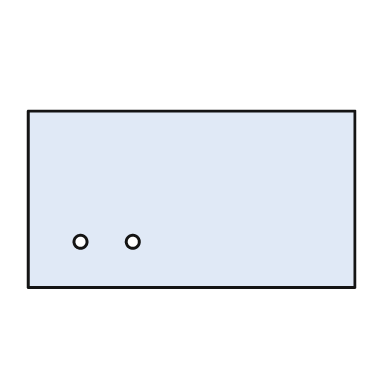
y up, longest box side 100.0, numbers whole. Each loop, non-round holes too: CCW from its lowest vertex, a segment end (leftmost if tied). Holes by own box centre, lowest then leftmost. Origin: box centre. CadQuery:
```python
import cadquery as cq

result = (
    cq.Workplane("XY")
    .moveTo(-50.0, -27.0)
    .lineTo(50.0, -27.0)
    .lineTo(50.0, 27.0)
    .lineTo(-50.0, 27.0)
    .close()
    .moveTo(-34.0, -13.0)
    .circle(2.0)
    .moveTo(-18.0, -13.0)
    .circle(2.0)
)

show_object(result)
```